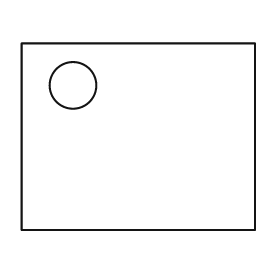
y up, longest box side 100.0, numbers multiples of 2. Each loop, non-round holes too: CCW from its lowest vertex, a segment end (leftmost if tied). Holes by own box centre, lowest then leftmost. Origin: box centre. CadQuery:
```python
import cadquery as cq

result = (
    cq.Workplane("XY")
    .moveTo(-50.0, -40.0)
    .lineTo(50.0, -40.0)
    .lineTo(50.0, 40.0)
    .lineTo(-50.0, 40.0)
    .close()
    .moveTo(-28.0, 22.0)
    .circle(10.0)
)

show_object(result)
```